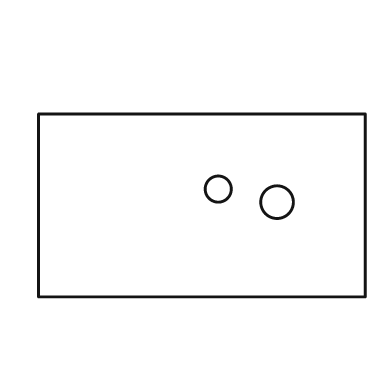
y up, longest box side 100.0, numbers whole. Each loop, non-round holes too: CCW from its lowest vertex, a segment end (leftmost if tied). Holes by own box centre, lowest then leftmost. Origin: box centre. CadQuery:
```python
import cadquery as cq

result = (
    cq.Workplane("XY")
    .moveTo(-50.0, -28.0)
    .lineTo(50.0, -28.0)
    .lineTo(50.0, 28.0)
    .lineTo(-50.0, 28.0)
    .close()
    .moveTo(23.0, 1.0)
    .circle(5.0)
    .moveTo(5.0, 5.0)
    .circle(4.0)
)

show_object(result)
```